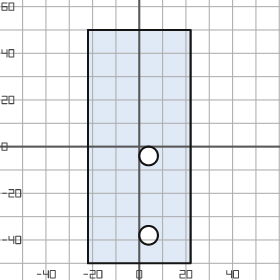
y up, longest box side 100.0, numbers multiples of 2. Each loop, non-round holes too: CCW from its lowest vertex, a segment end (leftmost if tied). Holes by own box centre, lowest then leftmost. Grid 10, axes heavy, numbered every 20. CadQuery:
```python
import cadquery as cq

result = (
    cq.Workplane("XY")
    .moveTo(-22.0, -50.0)
    .lineTo(22.0, -50.0)
    .lineTo(22.0, 50.0)
    .lineTo(-22.0, 50.0)
    .close()
    .moveTo(4.0, -38.0)
    .circle(4.0)
    .moveTo(4.0, -4.0)
    .circle(4.0)
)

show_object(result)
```